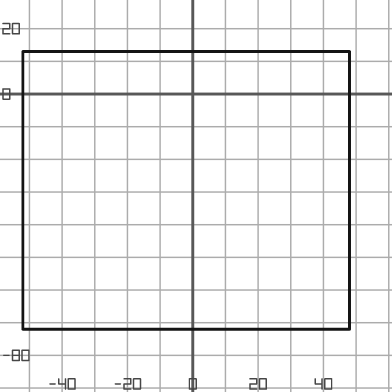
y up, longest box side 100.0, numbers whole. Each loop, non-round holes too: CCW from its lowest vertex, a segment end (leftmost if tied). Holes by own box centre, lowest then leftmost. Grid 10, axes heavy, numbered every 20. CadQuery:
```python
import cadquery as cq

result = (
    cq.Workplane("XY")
    .moveTo(-52.0, -72.0)
    .lineTo(48.0, -72.0)
    .lineTo(48.0, 13.0)
    .lineTo(-52.0, 13.0)
    .close()
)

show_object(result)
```